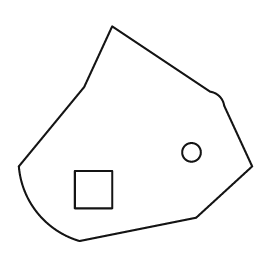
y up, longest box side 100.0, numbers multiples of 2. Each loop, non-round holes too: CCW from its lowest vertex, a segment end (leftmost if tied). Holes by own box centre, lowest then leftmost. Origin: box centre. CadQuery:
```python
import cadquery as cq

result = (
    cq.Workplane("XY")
    .moveTo(-24.0, -46.0)
    .lineTo(26.0, -36.0)
    .lineTo(50.0, -14.0)
    .lineTo(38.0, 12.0)
    .threePointArc((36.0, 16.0), (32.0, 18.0))
    .lineTo(-10.0, 46.0)
    .lineTo(-22.0, 20.0)
    .lineTo(-50.0, -14.0)
    .threePointArc((-42.0, -34.0), (-24.0, -46.0))
    .close()
    .moveTo(-26.0, -32.0)
    .lineTo(-10.0, -32.0)
    .lineTo(-10.0, -16.0)
    .lineTo(-26.0, -16.0)
    .close()
    .moveTo(24.0, -8.0)
    .circle(4.0)
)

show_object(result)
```